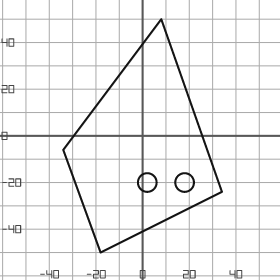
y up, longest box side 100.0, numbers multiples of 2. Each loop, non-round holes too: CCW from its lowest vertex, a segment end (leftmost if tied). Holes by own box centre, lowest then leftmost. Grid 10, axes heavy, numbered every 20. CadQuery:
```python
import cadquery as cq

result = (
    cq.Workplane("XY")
    .moveTo(-18.0, -50.0)
    .lineTo(34.0, -24.0)
    .lineTo(8.0, 50.0)
    .lineTo(-34.0, -6.0)
    .close()
    .moveTo(2.0, -20.0)
    .circle(4.0)
    .moveTo(18.0, -20.0)
    .circle(4.0)
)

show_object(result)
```